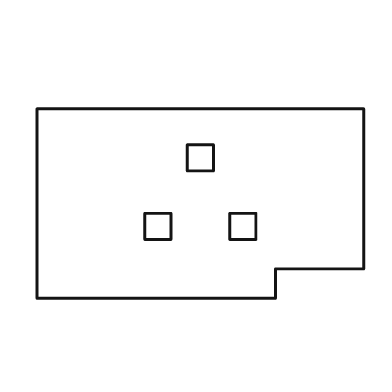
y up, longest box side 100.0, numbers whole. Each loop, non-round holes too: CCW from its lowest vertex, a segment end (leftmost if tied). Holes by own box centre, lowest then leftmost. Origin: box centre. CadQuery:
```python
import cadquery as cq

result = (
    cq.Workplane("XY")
    .moveTo(-50.0, -29.0)
    .lineTo(23.0, -29.0)
    .lineTo(23.0, -20.0)
    .lineTo(50.0, -20.0)
    .lineTo(50.0, 29.0)
    .lineTo(-50.0, 29.0)
    .close()
    .moveTo(-17.0, -11.0)
    .lineTo(-9.0, -11.0)
    .lineTo(-9.0, -3.0)
    .lineTo(-17.0, -3.0)
    .close()
    .moveTo(9.0, -11.0)
    .lineTo(17.0, -11.0)
    .lineTo(17.0, -3.0)
    .lineTo(9.0, -3.0)
    .close()
    .moveTo(-4.0, 10.0)
    .lineTo(4.0, 10.0)
    .lineTo(4.0, 18.0)
    .lineTo(-4.0, 18.0)
    .close()
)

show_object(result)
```